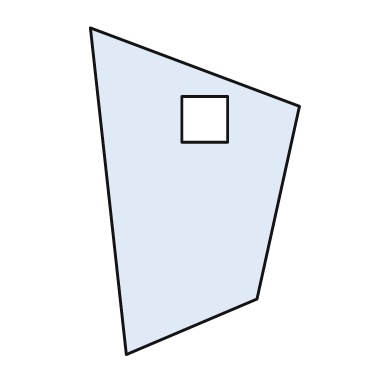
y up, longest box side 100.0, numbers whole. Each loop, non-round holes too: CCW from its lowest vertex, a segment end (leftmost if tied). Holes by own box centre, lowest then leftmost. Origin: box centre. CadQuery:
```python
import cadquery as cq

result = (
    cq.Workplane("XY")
    .moveTo(-21.0, -50.0)
    .lineTo(19.0, -33.0)
    .lineTo(32.0, 26.0)
    .lineTo(-32.0, 50.0)
    .close()
    .moveTo(-4.0, 15.0)
    .lineTo(10.0, 15.0)
    .lineTo(10.0, 29.0)
    .lineTo(-4.0, 29.0)
    .close()
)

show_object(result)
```